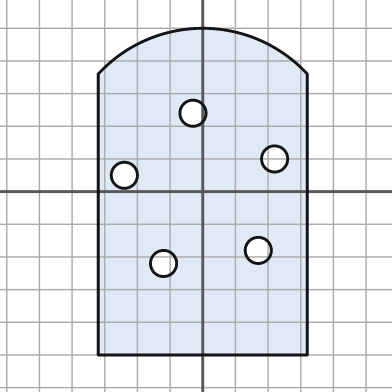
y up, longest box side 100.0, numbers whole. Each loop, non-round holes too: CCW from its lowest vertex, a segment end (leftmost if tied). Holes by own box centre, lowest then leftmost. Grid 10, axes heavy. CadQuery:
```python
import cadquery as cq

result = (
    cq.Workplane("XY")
    .moveTo(-32.0, -50.0)
    .lineTo(32.0, -50.0)
    .lineTo(32.0, 36.0)
    .threePointArc((0.0, 50.0), (-32.0, 36.0))
    .close()
    .moveTo(-12.0, -22.0)
    .circle(4.0)
    .moveTo(17.0, -18.0)
    .circle(4.0)
    .moveTo(-24.0, 5.0)
    .circle(4.0)
    .moveTo(22.0, 10.0)
    .circle(4.0)
    .moveTo(-3.0, 24.0)
    .circle(4.0)
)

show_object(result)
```